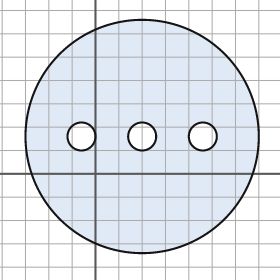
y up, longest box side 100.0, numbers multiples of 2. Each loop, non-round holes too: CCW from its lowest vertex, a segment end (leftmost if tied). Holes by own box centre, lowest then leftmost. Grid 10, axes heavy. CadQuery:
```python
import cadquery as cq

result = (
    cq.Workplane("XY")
    .moveTo(20.0, 16.0)
    .circle(50.0)
    .moveTo(-6.0, 16.0)
    .circle(6.0)
    .moveTo(20.0, 16.0)
    .circle(6.0)
    .moveTo(46.0, 16.0)
    .circle(6.0)
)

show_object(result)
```